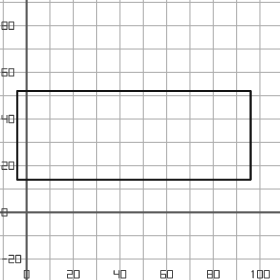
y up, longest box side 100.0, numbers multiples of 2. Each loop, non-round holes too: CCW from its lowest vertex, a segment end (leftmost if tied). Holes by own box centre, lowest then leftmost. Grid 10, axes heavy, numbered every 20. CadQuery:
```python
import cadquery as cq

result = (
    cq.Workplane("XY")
    .moveTo(-4.0, 14.0)
    .lineTo(96.0, 14.0)
    .lineTo(96.0, 52.0)
    .lineTo(-4.0, 52.0)
    .close()
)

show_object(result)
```